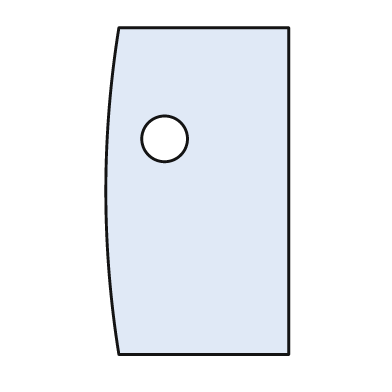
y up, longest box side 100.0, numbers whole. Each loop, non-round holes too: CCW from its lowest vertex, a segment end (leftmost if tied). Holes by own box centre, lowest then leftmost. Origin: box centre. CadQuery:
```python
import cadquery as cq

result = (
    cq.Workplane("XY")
    .moveTo(-24.0, -50.0)
    .lineTo(28.0, -50.0)
    .lineTo(28.0, 50.0)
    .lineTo(-24.0, 50.0)
    .threePointArc((-28.0, 0.0), (-24.0, -50.0))
    .close()
    .moveTo(-10.0, 16.0)
    .circle(7.0)
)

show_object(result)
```